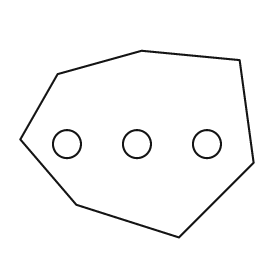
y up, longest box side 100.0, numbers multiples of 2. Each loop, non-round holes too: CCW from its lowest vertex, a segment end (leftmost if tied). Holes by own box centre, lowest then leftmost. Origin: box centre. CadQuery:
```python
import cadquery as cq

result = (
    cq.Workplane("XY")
    .moveTo(18.0, -40.0)
    .lineTo(50.0, -8.0)
    .lineTo(44.0, 36.0)
    .lineTo(2.0, 40.0)
    .lineTo(-34.0, 30.0)
    .lineTo(-50.0, 2.0)
    .lineTo(-26.0, -26.0)
    .close()
    .moveTo(-30.0, 0.0)
    .circle(6.0)
    .moveTo(0.0, 0.0)
    .circle(6.0)
    .moveTo(30.0, 0.0)
    .circle(6.0)
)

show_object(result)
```